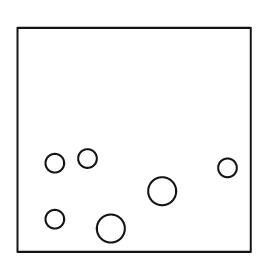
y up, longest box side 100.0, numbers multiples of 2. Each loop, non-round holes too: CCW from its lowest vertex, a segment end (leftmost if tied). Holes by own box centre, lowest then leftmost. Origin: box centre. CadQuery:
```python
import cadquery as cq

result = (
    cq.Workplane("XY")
    .moveTo(-50.0, -48.0)
    .lineTo(50.0, -48.0)
    .lineTo(50.0, 48.0)
    .lineTo(-50.0, 48.0)
    .close()
    .moveTo(-10.0, -38.0)
    .circle(6.0)
    .moveTo(-34.0, -34.0)
    .circle(4.0)
    .moveTo(12.0, -22.0)
    .circle(6.0)
    .moveTo(40.0, -12.0)
    .circle(4.0)
    .moveTo(-34.0, -10.0)
    .circle(4.0)
    .moveTo(-20.0, -8.0)
    .circle(4.0)
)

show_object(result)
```